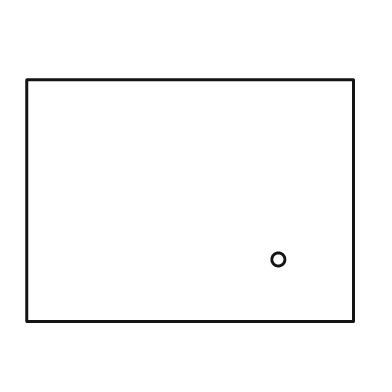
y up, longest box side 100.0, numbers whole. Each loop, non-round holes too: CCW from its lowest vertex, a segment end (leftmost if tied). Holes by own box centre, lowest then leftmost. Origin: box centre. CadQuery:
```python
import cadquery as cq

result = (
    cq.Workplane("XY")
    .moveTo(-50.0, -37.0)
    .lineTo(50.0, -37.0)
    .lineTo(50.0, 37.0)
    .lineTo(-50.0, 37.0)
    .close()
    .moveTo(27.0, -18.0)
    .circle(2.0)
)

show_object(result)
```